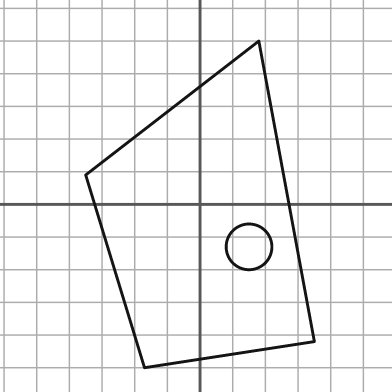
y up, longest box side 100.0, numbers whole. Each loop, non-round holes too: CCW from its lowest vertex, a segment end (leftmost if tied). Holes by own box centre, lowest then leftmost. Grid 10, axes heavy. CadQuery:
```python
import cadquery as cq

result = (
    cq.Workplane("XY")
    .moveTo(-17.0, -50.0)
    .lineTo(35.0, -42.0)
    .lineTo(18.0, 50.0)
    .lineTo(-35.0, 9.0)
    .close()
    .moveTo(15.0, -13.0)
    .circle(7.0)
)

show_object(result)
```